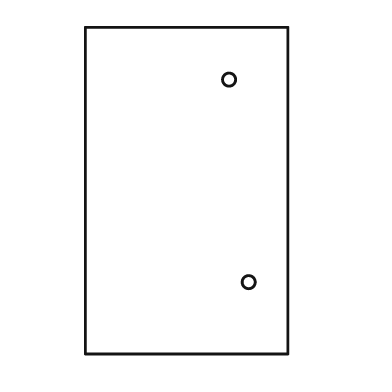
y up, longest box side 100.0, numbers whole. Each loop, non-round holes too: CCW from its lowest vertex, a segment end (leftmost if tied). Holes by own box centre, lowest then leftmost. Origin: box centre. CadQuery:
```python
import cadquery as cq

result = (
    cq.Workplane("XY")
    .moveTo(-31.0, -50.0)
    .lineTo(31.0, -50.0)
    .lineTo(31.0, 50.0)
    .lineTo(-31.0, 50.0)
    .close()
    .moveTo(19.0, -28.0)
    .circle(2.0)
    .moveTo(13.0, 34.0)
    .circle(2.0)
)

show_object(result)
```